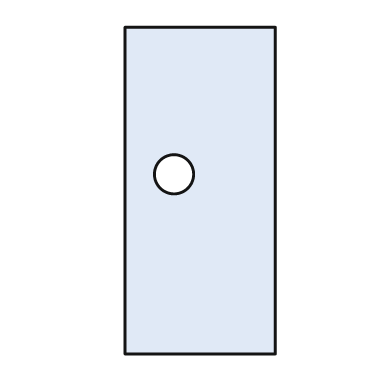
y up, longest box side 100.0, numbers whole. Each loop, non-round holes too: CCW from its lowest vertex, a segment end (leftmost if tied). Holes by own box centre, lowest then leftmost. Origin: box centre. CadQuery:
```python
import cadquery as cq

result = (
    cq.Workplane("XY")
    .moveTo(-23.0, -50.0)
    .lineTo(23.0, -50.0)
    .lineTo(23.0, 50.0)
    .lineTo(-23.0, 50.0)
    .close()
    .moveTo(-8.0, 5.0)
    .circle(6.0)
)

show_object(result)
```